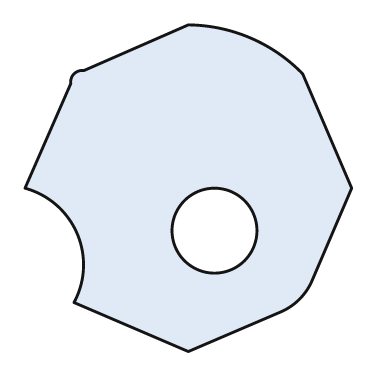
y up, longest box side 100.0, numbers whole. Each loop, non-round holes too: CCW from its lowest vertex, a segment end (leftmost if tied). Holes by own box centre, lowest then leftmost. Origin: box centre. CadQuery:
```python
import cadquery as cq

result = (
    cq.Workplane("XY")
    .moveTo(0.0, -50.0)
    .lineTo(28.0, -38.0)
    .threePointArc((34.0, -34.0), (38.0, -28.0))
    .lineTo(50.0, 0.0)
    .lineTo(35.0, 35.0)
    .threePointArc((19.0, 46.0), (0.0, 50.0))
    .lineTo(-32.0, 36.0)
    .threePointArc((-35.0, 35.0), (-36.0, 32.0))
    .lineTo(-50.0, 0.0)
    .threePointArc((-34.0, -14.0), (-35.0, -35.0))
    .close()
    .moveTo(8.0, -13.0)
    .circle(13.0)
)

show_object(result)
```